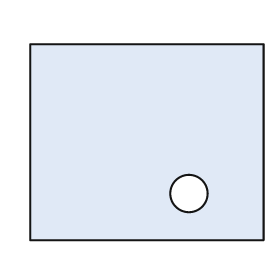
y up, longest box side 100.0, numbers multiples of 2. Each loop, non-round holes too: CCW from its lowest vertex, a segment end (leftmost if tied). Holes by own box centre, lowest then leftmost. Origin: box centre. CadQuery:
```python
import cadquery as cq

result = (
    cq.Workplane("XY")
    .moveTo(-50.0, -42.0)
    .lineTo(50.0, -42.0)
    .lineTo(50.0, 42.0)
    .lineTo(-50.0, 42.0)
    .close()
    .moveTo(18.0, -22.0)
    .circle(8.0)
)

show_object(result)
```